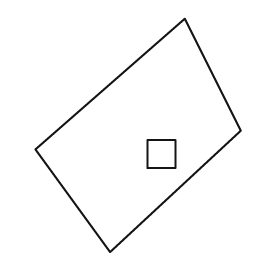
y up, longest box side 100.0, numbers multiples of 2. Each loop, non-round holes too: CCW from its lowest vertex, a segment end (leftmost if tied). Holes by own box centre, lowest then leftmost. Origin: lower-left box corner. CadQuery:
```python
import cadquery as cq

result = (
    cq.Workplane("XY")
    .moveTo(32.0, 0.0)
    .lineTo(88.0, 52.0)
    .lineTo(64.0, 100.0)
    .lineTo(0.0, 44.0)
    .close()
    .moveTo(48.0, 36.0)
    .lineTo(60.0, 36.0)
    .lineTo(60.0, 48.0)
    .lineTo(48.0, 48.0)
    .close()
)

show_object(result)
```